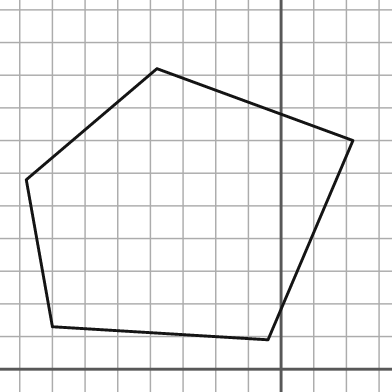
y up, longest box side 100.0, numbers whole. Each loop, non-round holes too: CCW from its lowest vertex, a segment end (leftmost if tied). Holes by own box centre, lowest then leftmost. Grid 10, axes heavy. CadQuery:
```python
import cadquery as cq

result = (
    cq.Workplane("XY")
    .moveTo(-4.0, 9.0)
    .lineTo(22.0, 70.0)
    .lineTo(-38.0, 92.0)
    .lineTo(-78.0, 58.0)
    .lineTo(-70.0, 13.0)
    .close()
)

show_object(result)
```